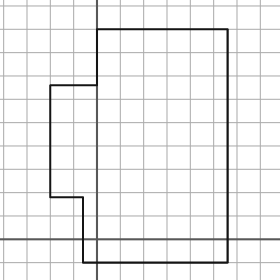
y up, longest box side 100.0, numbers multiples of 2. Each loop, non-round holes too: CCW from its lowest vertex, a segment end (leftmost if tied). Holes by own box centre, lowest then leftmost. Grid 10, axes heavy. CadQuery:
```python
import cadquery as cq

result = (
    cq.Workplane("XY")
    .moveTo(-6.0, -10.0)
    .lineTo(56.0, -10.0)
    .lineTo(56.0, 90.0)
    .lineTo(0.0, 90.0)
    .lineTo(0.0, 66.0)
    .lineTo(-20.0, 66.0)
    .lineTo(-20.0, 18.0)
    .lineTo(-6.0, 18.0)
    .close()
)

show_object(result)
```